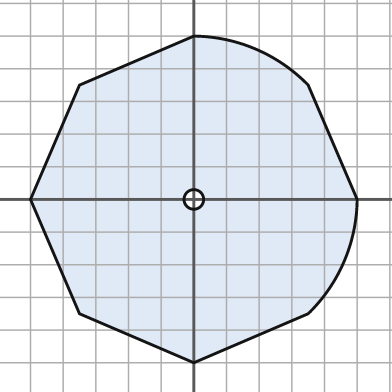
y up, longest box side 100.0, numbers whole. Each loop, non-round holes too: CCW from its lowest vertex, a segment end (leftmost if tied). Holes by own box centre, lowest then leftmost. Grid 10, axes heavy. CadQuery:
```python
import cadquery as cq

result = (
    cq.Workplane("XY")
    .moveTo(0.0, -50.0)
    .lineTo(35.0, -35.0)
    .threePointArc((46.0, -19.0), (50.0, 0.0))
    .lineTo(35.0, 35.0)
    .threePointArc((19.0, 46.0), (0.0, 50.0))
    .lineTo(-35.0, 35.0)
    .lineTo(-50.0, 0.0)
    .lineTo(-35.0, -35.0)
    .close()
    .moveTo(0.0, 0.0)
    .circle(3.0)
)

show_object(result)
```